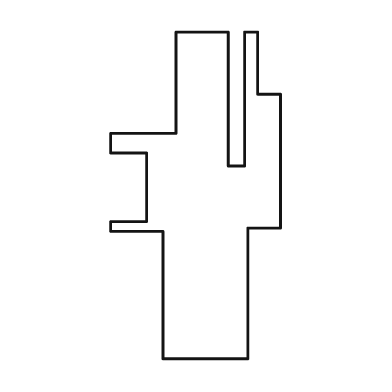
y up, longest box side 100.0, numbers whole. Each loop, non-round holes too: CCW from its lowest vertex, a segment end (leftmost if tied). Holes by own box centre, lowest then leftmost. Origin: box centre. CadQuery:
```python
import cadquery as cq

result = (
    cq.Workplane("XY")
    .moveTo(-10.0, -50.0)
    .lineTo(16.0, -50.0)
    .lineTo(16.0, -10.0)
    .lineTo(26.0, -10.0)
    .lineTo(26.0, 31.0)
    .lineTo(19.0, 31.0)
    .lineTo(19.0, 50.0)
    .lineTo(15.0, 50.0)
    .lineTo(15.0, 9.0)
    .lineTo(10.0, 9.0)
    .lineTo(10.0, 50.0)
    .lineTo(-6.0, 50.0)
    .lineTo(-6.0, 19.0)
    .lineTo(-26.0, 19.0)
    .lineTo(-26.0, 13.0)
    .lineTo(-15.0, 13.0)
    .lineTo(-15.0, -8.0)
    .lineTo(-26.0, -8.0)
    .lineTo(-26.0, -11.0)
    .lineTo(-10.0, -11.0)
    .close()
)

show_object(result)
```